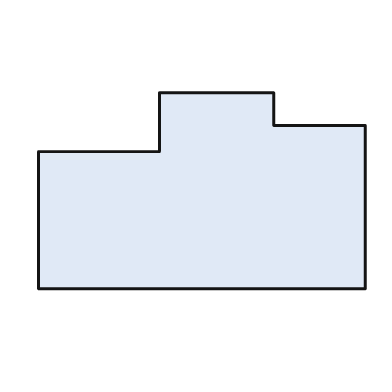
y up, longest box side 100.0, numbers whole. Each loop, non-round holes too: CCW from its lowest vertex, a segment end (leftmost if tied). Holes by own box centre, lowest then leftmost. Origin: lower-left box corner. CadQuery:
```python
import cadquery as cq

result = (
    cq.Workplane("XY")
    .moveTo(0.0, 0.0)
    .lineTo(100.0, 0.0)
    .lineTo(100.0, 50.0)
    .lineTo(72.0, 50.0)
    .lineTo(72.0, 60.0)
    .lineTo(37.0, 60.0)
    .lineTo(37.0, 42.0)
    .lineTo(0.0, 42.0)
    .close()
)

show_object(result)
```